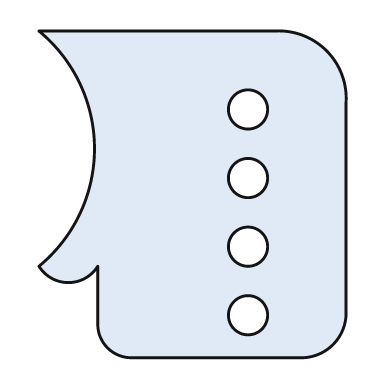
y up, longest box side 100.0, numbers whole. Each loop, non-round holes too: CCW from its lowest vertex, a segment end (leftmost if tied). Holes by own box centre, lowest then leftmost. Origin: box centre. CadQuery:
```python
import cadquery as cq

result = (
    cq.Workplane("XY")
    .moveTo(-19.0, -50.0)
    .lineTo(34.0, -50.0)
    .threePointArc((43.0, -46.0), (47.0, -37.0))
    .lineTo(47.0, 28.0)
    .threePointArc((41.0, 44.0), (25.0, 50.0))
    .lineTo(-47.0, 50.0)
    .threePointArc((-30.0, 14.0), (-47.0, -22.0))
    .threePointArc((-38.0, -27.0), (-29.0, -22.0))
    .lineTo(-29.0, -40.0)
    .threePointArc((-26.0, -47.0), (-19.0, -50.0))
    .close()
    .moveTo(17.0, -37.0)
    .circle(6.0)
    .moveTo(17.0, -16.0)
    .circle(6.0)
    .moveTo(17.0, 5.0)
    .circle(6.0)
    .moveTo(17.0, 26.0)
    .circle(6.0)
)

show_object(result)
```